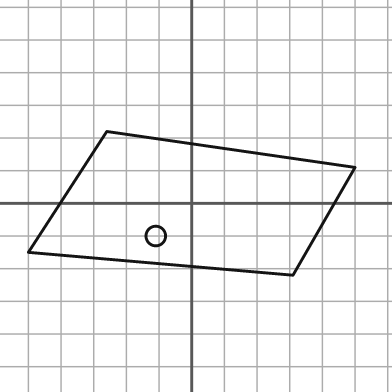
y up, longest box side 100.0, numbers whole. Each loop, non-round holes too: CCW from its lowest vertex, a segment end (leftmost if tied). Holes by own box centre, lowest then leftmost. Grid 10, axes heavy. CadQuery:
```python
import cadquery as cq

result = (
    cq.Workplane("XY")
    .moveTo(31.0, -22.0)
    .lineTo(50.0, 11.0)
    .lineTo(-26.0, 22.0)
    .lineTo(-50.0, -15.0)
    .close()
    .moveTo(-11.0, -10.0)
    .circle(3.0)
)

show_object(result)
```